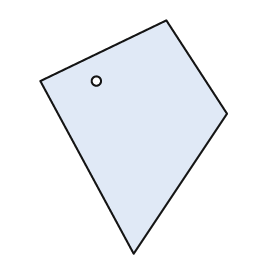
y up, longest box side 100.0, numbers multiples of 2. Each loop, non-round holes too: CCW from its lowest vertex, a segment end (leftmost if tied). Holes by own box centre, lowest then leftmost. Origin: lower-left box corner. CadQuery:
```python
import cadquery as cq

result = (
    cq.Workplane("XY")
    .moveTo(40.0, 0.0)
    .lineTo(80.0, 60.0)
    .lineTo(54.0, 100.0)
    .lineTo(0.0, 74.0)
    .close()
    .moveTo(24.0, 74.0)
    .circle(2.0)
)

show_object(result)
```